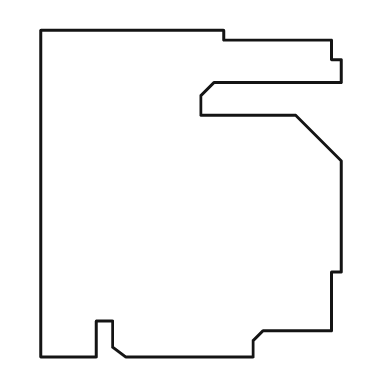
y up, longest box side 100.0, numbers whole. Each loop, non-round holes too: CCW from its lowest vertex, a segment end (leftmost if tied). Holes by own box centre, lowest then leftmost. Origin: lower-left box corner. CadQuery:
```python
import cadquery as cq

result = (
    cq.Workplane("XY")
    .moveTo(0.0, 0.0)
    .lineTo(17.0, 0.0)
    .lineTo(17.0, 11.0)
    .lineTo(22.0, 11.0)
    .lineTo(22.0, 3.0)
    .lineTo(26.0, 0.0)
    .lineTo(65.0, 0.0)
    .lineTo(65.0, 5.0)
    .lineTo(68.0, 8.0)
    .lineTo(89.0, 8.0)
    .lineTo(89.0, 26.0)
    .lineTo(92.0, 26.0)
    .lineTo(92.0, 60.0)
    .lineTo(78.0, 74.0)
    .lineTo(49.0, 74.0)
    .lineTo(49.0, 80.0)
    .lineTo(53.0, 84.0)
    .lineTo(92.0, 84.0)
    .lineTo(92.0, 91.0)
    .lineTo(89.0, 91.0)
    .lineTo(89.0, 97.0)
    .lineTo(56.0, 97.0)
    .lineTo(56.0, 100.0)
    .lineTo(0.0, 100.0)
    .close()
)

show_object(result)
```